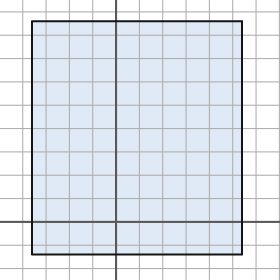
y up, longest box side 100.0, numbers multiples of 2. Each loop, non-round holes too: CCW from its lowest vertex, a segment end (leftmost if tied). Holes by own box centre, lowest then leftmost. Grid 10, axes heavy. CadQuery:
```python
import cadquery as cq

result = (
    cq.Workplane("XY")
    .moveTo(-36.0, -14.0)
    .lineTo(54.0, -14.0)
    .lineTo(54.0, 86.0)
    .lineTo(-36.0, 86.0)
    .close()
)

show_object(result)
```